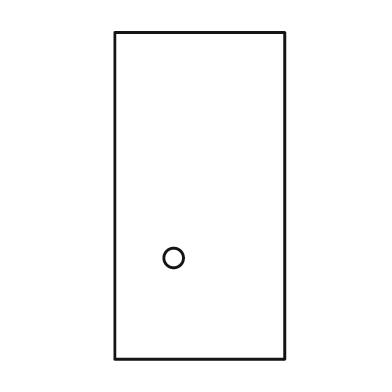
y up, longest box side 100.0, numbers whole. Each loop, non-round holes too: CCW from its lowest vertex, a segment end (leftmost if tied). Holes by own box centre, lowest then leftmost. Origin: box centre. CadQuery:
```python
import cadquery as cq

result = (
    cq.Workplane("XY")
    .moveTo(-26.0, -50.0)
    .lineTo(26.0, -50.0)
    .lineTo(26.0, 50.0)
    .lineTo(-26.0, 50.0)
    .close()
    .moveTo(-8.0, -19.0)
    .circle(3.0)
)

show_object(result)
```